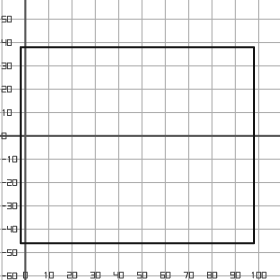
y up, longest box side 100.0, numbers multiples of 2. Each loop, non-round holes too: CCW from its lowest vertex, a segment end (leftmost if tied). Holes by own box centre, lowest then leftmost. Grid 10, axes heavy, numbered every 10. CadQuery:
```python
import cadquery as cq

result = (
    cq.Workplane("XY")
    .moveTo(-2.0, -46.0)
    .lineTo(98.0, -46.0)
    .lineTo(98.0, 38.0)
    .lineTo(-2.0, 38.0)
    .close()
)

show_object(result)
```